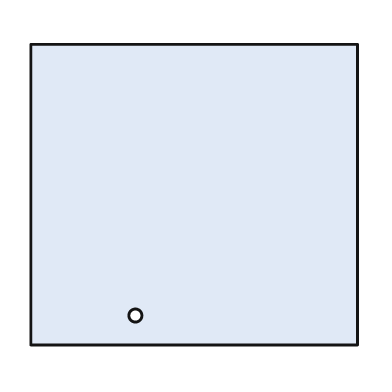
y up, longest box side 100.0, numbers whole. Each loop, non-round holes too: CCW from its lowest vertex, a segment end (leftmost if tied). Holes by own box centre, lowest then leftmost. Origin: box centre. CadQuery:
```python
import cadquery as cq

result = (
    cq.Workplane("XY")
    .moveTo(-50.0, -46.0)
    .lineTo(50.0, -46.0)
    .lineTo(50.0, 46.0)
    .lineTo(-50.0, 46.0)
    .close()
    .moveTo(-18.0, -37.0)
    .circle(2.0)
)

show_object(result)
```